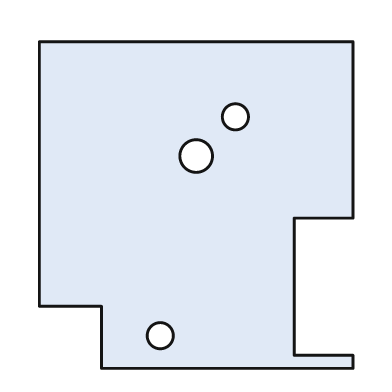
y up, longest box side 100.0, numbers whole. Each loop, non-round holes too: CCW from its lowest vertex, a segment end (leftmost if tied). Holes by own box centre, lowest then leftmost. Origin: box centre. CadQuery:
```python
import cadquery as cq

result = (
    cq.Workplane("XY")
    .moveTo(-29.0, -50.0)
    .lineTo(48.0, -50.0)
    .lineTo(48.0, -46.0)
    .lineTo(30.0, -46.0)
    .lineTo(30.0, -4.0)
    .lineTo(48.0, -4.0)
    .lineTo(48.0, 50.0)
    .lineTo(-48.0, 50.0)
    .lineTo(-48.0, -31.0)
    .lineTo(-29.0, -31.0)
    .close()
    .moveTo(-11.0, -40.0)
    .circle(4.0)
    .moveTo(0.0, 15.0)
    .circle(5.0)
    .moveTo(12.0, 27.0)
    .circle(4.0)
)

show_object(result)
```